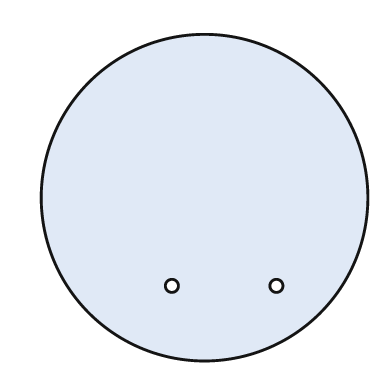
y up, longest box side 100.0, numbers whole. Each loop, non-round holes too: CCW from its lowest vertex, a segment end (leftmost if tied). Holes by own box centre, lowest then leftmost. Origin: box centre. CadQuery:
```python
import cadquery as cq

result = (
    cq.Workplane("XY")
    .moveTo(0.0, 0.0)
    .circle(50.0)
    .moveTo(-10.0, -27.0)
    .circle(2.0)
    .moveTo(22.0, -27.0)
    .circle(2.0)
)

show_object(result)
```